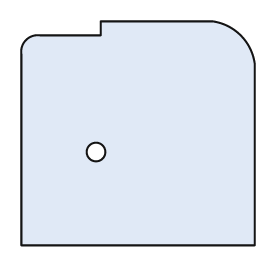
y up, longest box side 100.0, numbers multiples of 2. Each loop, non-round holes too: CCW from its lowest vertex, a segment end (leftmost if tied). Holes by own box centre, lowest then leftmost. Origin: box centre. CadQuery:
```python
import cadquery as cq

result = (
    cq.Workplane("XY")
    .moveTo(-50.0, -48.0)
    .lineTo(50.0, -48.0)
    .lineTo(50.0, 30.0)
    .threePointArc((44.0, 42.0), (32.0, 48.0))
    .lineTo(-16.0, 48.0)
    .lineTo(-16.0, 42.0)
    .lineTo(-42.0, 42.0)
    .threePointArc((-48.0, 40.0), (-50.0, 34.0))
    .close()
    .moveTo(-18.0, -8.0)
    .circle(4.0)
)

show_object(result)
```